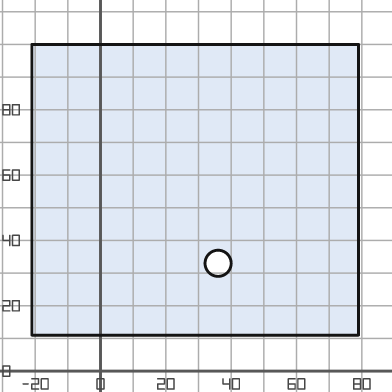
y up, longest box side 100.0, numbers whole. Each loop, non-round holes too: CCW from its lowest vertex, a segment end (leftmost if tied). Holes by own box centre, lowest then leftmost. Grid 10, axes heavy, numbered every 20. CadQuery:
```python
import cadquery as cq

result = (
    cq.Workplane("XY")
    .moveTo(-21.0, 11.0)
    .lineTo(79.0, 11.0)
    .lineTo(79.0, 100.0)
    .lineTo(-21.0, 100.0)
    .close()
    .moveTo(36.0, 33.0)
    .circle(4.0)
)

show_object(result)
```